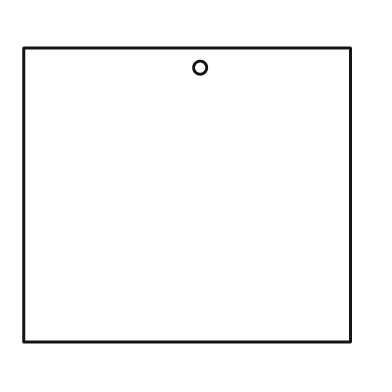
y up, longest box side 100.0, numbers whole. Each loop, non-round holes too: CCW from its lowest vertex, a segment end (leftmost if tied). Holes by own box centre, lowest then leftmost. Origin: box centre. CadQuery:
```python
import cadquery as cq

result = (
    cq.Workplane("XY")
    .moveTo(-50.0, -45.0)
    .lineTo(50.0, -45.0)
    .lineTo(50.0, 45.0)
    .lineTo(-50.0, 45.0)
    .close()
    .moveTo(4.0, 39.0)
    .circle(2.0)
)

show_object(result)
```